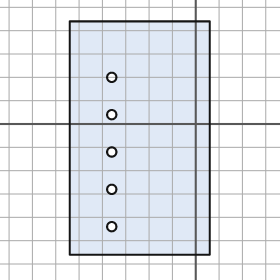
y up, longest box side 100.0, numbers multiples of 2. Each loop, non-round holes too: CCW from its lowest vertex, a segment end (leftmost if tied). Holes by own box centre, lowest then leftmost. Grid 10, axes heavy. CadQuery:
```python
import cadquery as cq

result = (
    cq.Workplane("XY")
    .moveTo(-54.0, -56.0)
    .lineTo(6.0, -56.0)
    .lineTo(6.0, 44.0)
    .lineTo(-54.0, 44.0)
    .close()
    .moveTo(-36.0, -44.0)
    .circle(2.0)
    .moveTo(-36.0, -28.0)
    .circle(2.0)
    .moveTo(-36.0, -12.0)
    .circle(2.0)
    .moveTo(-36.0, 4.0)
    .circle(2.0)
    .moveTo(-36.0, 20.0)
    .circle(2.0)
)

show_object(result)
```